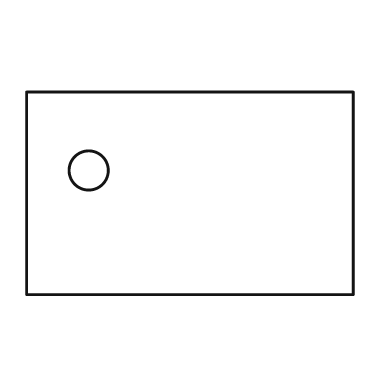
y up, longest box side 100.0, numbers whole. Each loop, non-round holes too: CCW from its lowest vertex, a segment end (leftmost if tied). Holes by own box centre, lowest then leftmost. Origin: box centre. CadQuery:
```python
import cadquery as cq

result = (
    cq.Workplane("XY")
    .moveTo(-50.0, -31.0)
    .lineTo(50.0, -31.0)
    .lineTo(50.0, 31.0)
    .lineTo(-50.0, 31.0)
    .close()
    .moveTo(-31.0, 7.0)
    .circle(6.0)
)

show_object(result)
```